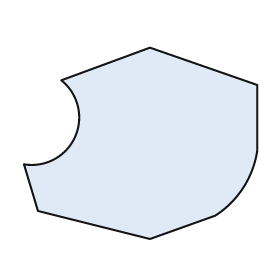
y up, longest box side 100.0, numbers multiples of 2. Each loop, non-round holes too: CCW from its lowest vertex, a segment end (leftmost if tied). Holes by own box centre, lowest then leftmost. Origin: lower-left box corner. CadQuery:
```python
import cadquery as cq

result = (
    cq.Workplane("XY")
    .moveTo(54.0, 0.0)
    .lineTo(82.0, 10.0)
    .threePointArc((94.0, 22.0), (100.0, 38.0))
    .lineTo(100.0, 66.0)
    .lineTo(54.0, 82.0)
    .lineTo(16.0, 68.0)
    .threePointArc((22.0, 44.0), (0.0, 32.0))
    .lineTo(6.0, 12.0)
    .close()
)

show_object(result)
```